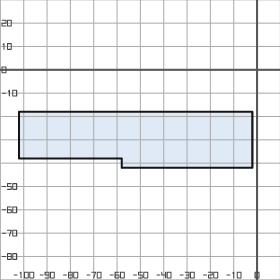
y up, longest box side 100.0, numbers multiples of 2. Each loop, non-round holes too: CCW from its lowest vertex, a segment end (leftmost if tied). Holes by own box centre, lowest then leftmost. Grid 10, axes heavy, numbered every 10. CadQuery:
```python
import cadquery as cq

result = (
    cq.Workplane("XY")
    .moveTo(-58.0, -42.0)
    .lineTo(-2.0, -42.0)
    .lineTo(-2.0, -18.0)
    .lineTo(-102.0, -18.0)
    .lineTo(-102.0, -38.0)
    .lineTo(-58.0, -38.0)
    .close()
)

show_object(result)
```